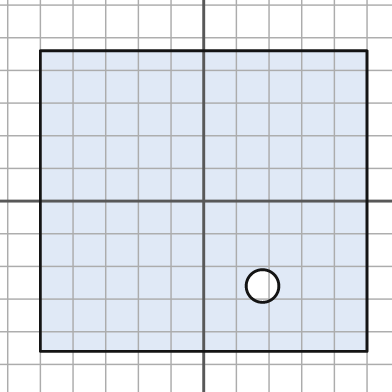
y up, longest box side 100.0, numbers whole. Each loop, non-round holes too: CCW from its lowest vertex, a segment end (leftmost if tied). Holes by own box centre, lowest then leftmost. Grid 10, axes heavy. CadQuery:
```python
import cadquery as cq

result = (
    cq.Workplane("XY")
    .moveTo(-50.0, -46.0)
    .lineTo(50.0, -46.0)
    .lineTo(50.0, 46.0)
    .lineTo(-50.0, 46.0)
    .close()
    .moveTo(18.0, -26.0)
    .circle(5.0)
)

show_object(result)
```